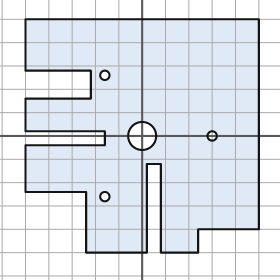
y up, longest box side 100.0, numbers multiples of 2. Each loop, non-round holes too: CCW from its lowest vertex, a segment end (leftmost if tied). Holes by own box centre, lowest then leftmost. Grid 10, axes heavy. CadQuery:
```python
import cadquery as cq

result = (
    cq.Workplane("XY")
    .moveTo(-24.0, -50.0)
    .lineTo(2.0, -50.0)
    .lineTo(2.0, -12.0)
    .lineTo(8.0, -12.0)
    .lineTo(8.0, -50.0)
    .lineTo(24.0, -50.0)
    .lineTo(24.0, -40.0)
    .lineTo(50.0, -40.0)
    .lineTo(50.0, 50.0)
    .lineTo(-50.0, 50.0)
    .lineTo(-50.0, 28.0)
    .lineTo(-22.0, 28.0)
    .lineTo(-22.0, 16.0)
    .lineTo(-50.0, 16.0)
    .lineTo(-50.0, 2.0)
    .lineTo(-16.0, 2.0)
    .lineTo(-16.0, -4.0)
    .lineTo(-50.0, -4.0)
    .lineTo(-50.0, -24.0)
    .lineTo(-24.0, -24.0)
    .close()
    .moveTo(-16.0, -26.0)
    .circle(2.0)
    .moveTo(0.0, 0.0)
    .circle(6.0)
    .moveTo(30.0, 0.0)
    .circle(2.0)
    .moveTo(-16.0, 26.0)
    .circle(2.0)
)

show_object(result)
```